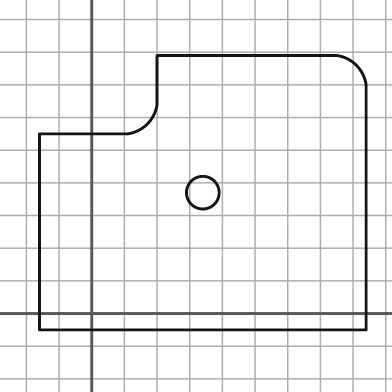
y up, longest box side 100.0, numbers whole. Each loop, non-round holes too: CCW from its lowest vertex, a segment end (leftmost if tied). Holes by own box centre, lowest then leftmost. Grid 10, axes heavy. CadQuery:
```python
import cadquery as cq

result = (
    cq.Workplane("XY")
    .moveTo(-16.0, -5.0)
    .lineTo(84.0, -5.0)
    .lineTo(84.0, 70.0)
    .threePointArc((81.0, 76.0), (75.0, 79.0))
    .lineTo(20.0, 79.0)
    .lineTo(20.0, 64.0)
    .threePointArc((17.0, 58.0), (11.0, 55.0))
    .lineTo(-16.0, 55.0)
    .close()
    .moveTo(34.0, 37.0)
    .circle(5.0)
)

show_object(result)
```